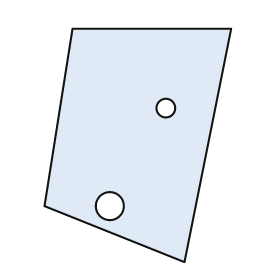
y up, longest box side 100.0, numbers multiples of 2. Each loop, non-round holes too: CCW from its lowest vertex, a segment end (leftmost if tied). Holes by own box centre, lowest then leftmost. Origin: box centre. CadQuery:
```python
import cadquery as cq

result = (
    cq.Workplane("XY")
    .moveTo(20.0, -50.0)
    .lineTo(40.0, 50.0)
    .lineTo(-28.0, 50.0)
    .lineTo(-40.0, -26.0)
    .close()
    .moveTo(-12.0, -26.0)
    .circle(6.0)
    .moveTo(12.0, 16.0)
    .circle(4.0)
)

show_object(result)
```